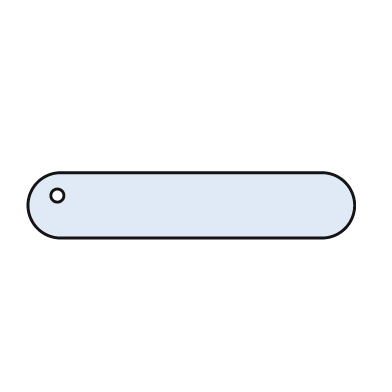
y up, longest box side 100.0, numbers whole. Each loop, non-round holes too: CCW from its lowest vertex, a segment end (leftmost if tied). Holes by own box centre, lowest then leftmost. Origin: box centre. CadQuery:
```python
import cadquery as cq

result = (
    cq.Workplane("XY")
    .moveTo(-40.0, -10.0)
    .lineTo(40.0, -10.0)
    .threePointArc((50.0, 0.0), (40.0, 10.0))
    .lineTo(-40.0, 10.0)
    .threePointArc((-50.0, 0.0), (-40.0, -10.0))
    .close()
    .moveTo(-41.0, 3.0)
    .circle(2.0)
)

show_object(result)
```